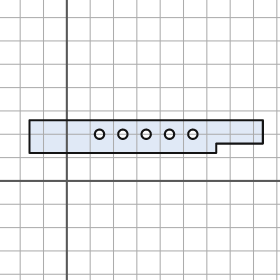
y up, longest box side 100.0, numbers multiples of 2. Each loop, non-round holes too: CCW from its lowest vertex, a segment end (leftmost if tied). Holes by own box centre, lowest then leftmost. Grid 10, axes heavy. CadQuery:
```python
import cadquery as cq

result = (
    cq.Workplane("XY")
    .moveTo(-16.0, 12.0)
    .lineTo(64.0, 12.0)
    .lineTo(64.0, 16.0)
    .lineTo(84.0, 16.0)
    .lineTo(84.0, 26.0)
    .lineTo(-16.0, 26.0)
    .close()
    .moveTo(14.0, 20.0)
    .circle(2.0)
    .moveTo(24.0, 20.0)
    .circle(2.0)
    .moveTo(34.0, 20.0)
    .circle(2.0)
    .moveTo(44.0, 20.0)
    .circle(2.0)
    .moveTo(54.0, 20.0)
    .circle(2.0)
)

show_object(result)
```